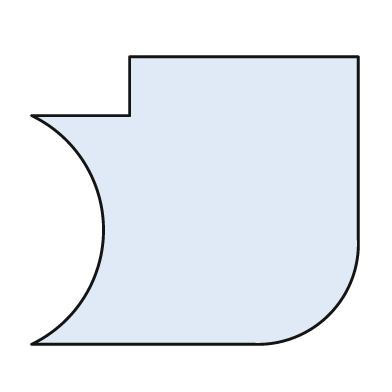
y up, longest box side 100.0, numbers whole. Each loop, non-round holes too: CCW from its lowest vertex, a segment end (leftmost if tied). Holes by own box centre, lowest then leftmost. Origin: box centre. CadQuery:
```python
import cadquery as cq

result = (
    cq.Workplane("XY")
    .moveTo(-50.0, -44.0)
    .lineTo(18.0, -44.0)
    .threePointArc((41.0, -35.0), (50.0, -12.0))
    .lineTo(50.0, 44.0)
    .lineTo(-20.0, 44.0)
    .lineTo(-20.0, 26.0)
    .lineTo(-50.0, 26.0)
    .threePointArc((-28.0, -9.0), (-50.0, -44.0))
    .close()
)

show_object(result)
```